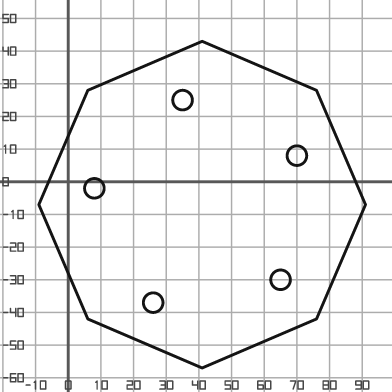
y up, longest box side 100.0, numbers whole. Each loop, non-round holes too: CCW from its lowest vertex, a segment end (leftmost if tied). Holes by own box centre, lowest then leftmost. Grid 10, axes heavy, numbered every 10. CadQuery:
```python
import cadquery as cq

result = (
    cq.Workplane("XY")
    .moveTo(41.0, -57.0)
    .lineTo(76.0, -42.0)
    .lineTo(91.0, -7.0)
    .lineTo(76.0, 28.0)
    .lineTo(41.0, 43.0)
    .lineTo(6.0, 28.0)
    .lineTo(-9.0, -7.0)
    .lineTo(6.0, -42.0)
    .close()
    .moveTo(26.0, -37.0)
    .circle(3.0)
    .moveTo(65.0, -30.0)
    .circle(3.0)
    .moveTo(8.0, -2.0)
    .circle(3.0)
    .moveTo(70.0, 8.0)
    .circle(3.0)
    .moveTo(35.0, 25.0)
    .circle(3.0)
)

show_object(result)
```